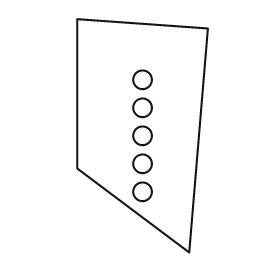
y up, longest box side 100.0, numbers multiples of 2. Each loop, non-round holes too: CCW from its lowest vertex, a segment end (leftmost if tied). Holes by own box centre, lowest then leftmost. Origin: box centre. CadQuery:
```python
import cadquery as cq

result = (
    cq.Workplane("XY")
    .moveTo(20.0, -50.0)
    .lineTo(28.0, 46.0)
    .lineTo(-28.0, 50.0)
    .lineTo(-28.0, -14.0)
    .close()
    .moveTo(0.0, -24.0)
    .circle(4.0)
    .moveTo(0.0, -12.0)
    .circle(4.0)
    .moveTo(0.0, 0.0)
    .circle(4.0)
    .moveTo(0.0, 12.0)
    .circle(4.0)
    .moveTo(0.0, 24.0)
    .circle(4.0)
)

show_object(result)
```